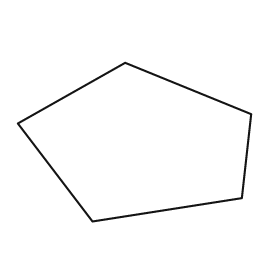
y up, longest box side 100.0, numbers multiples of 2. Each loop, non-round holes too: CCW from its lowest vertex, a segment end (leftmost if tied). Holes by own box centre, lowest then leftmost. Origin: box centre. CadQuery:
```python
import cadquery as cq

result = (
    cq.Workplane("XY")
    .moveTo(-18.0, -34.0)
    .lineTo(46.0, -24.0)
    .lineTo(50.0, 12.0)
    .lineTo(-4.0, 34.0)
    .lineTo(-50.0, 8.0)
    .close()
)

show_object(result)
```